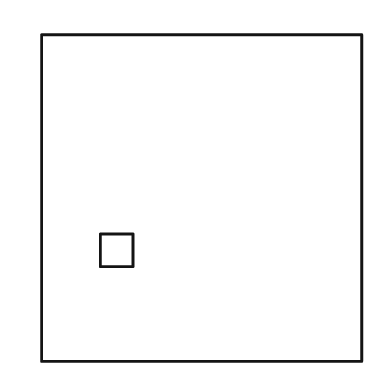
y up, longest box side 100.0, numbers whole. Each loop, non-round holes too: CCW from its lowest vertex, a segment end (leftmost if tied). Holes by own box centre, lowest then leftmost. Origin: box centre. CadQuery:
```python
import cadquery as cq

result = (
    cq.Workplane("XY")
    .moveTo(-49.0, -50.0)
    .lineTo(49.0, -50.0)
    .lineTo(49.0, 50.0)
    .lineTo(-49.0, 50.0)
    .close()
    .moveTo(-31.0, -21.0)
    .lineTo(-21.0, -21.0)
    .lineTo(-21.0, -11.0)
    .lineTo(-31.0, -11.0)
    .close()
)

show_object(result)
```